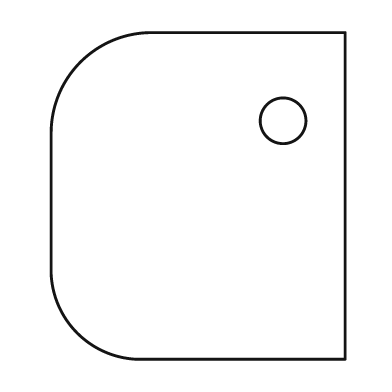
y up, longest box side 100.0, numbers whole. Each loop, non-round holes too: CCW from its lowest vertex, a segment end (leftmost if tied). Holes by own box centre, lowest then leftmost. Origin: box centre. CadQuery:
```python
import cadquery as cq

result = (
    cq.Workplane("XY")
    .moveTo(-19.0, -50.0)
    .lineTo(45.0, -50.0)
    .lineTo(45.0, 50.0)
    .lineTo(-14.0, 50.0)
    .threePointArc((-36.0, 41.0), (-45.0, 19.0))
    .lineTo(-45.0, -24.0)
    .threePointArc((-37.0, -42.0), (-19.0, -50.0))
    .close()
    .moveTo(26.0, 23.0)
    .circle(7.0)
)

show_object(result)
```